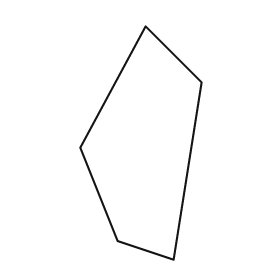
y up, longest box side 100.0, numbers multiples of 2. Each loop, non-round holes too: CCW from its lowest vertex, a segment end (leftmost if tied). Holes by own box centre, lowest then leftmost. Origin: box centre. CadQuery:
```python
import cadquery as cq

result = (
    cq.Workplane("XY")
    .moveTo(14.0, -50.0)
    .lineTo(26.0, 26.0)
    .lineTo(2.0, 50.0)
    .lineTo(-26.0, -2.0)
    .lineTo(-10.0, -42.0)
    .close()
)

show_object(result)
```